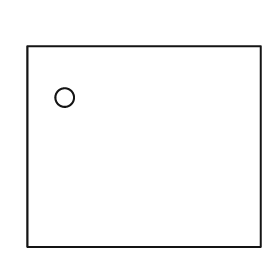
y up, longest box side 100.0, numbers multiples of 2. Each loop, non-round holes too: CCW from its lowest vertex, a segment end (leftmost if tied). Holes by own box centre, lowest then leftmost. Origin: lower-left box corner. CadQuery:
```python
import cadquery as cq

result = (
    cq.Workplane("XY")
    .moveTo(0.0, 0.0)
    .lineTo(100.0, 0.0)
    .lineTo(100.0, 86.0)
    .lineTo(0.0, 86.0)
    .close()
    .moveTo(16.0, 64.0)
    .circle(4.0)
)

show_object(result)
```